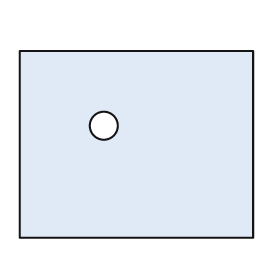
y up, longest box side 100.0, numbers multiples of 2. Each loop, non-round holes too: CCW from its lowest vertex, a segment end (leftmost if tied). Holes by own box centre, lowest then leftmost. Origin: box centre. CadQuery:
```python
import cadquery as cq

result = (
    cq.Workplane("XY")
    .moveTo(-50.0, -40.0)
    .lineTo(50.0, -40.0)
    .lineTo(50.0, 40.0)
    .lineTo(-50.0, 40.0)
    .close()
    .moveTo(-14.0, 8.0)
    .circle(6.0)
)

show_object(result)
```